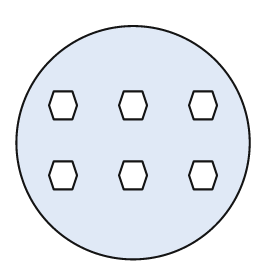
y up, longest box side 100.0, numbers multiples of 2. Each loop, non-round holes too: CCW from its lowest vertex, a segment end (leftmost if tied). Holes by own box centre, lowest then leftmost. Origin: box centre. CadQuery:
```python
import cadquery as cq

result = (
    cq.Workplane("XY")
    .moveTo(0.0, 0.0)
    .circle(50.0)
    .moveTo(-34.0, -20.0)
    .lineTo(-26.0, -20.0)
    .lineTo(-24.0, -14.0)
    .lineTo(-26.0, -8.0)
    .lineTo(-34.0, -8.0)
    .lineTo(-36.0, -14.0)
    .close()
    .moveTo(-4.0, -20.0)
    .lineTo(4.0, -20.0)
    .lineTo(6.0, -14.0)
    .lineTo(4.0, -8.0)
    .lineTo(-4.0, -8.0)
    .lineTo(-6.0, -14.0)
    .close()
    .moveTo(26.0, -20.0)
    .lineTo(34.0, -20.0)
    .lineTo(36.0, -14.0)
    .lineTo(34.0, -8.0)
    .lineTo(26.0, -8.0)
    .lineTo(24.0, -14.0)
    .close()
    .moveTo(-34.0, 10.0)
    .lineTo(-26.0, 10.0)
    .lineTo(-24.0, 16.0)
    .lineTo(-26.0, 22.0)
    .lineTo(-34.0, 22.0)
    .lineTo(-36.0, 16.0)
    .close()
    .moveTo(-4.0, 10.0)
    .lineTo(4.0, 10.0)
    .lineTo(6.0, 16.0)
    .lineTo(4.0, 22.0)
    .lineTo(-4.0, 22.0)
    .lineTo(-6.0, 16.0)
    .close()
    .moveTo(26.0, 10.0)
    .lineTo(34.0, 10.0)
    .lineTo(36.0, 16.0)
    .lineTo(34.0, 22.0)
    .lineTo(26.0, 22.0)
    .lineTo(24.0, 16.0)
    .close()
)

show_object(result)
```